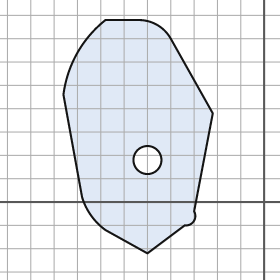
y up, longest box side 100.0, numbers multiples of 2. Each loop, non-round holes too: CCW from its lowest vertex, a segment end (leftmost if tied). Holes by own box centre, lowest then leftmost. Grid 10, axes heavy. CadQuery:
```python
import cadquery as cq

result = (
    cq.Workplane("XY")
    .moveTo(-50.0, -22.0)
    .lineTo(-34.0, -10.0)
    .threePointArc((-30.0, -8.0), (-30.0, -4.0))
    .lineTo(-22.0, 38.0)
    .lineTo(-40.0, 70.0)
    .threePointArc((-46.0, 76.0), (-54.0, 78.0))
    .lineTo(-68.0, 78.0)
    .threePointArc((-80.0, 64.0), (-86.0, 46.0))
    .lineTo(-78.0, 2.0)
    .threePointArc((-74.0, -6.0), (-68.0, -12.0))
    .close()
    .moveTo(-50.0, 18.0)
    .circle(6.0)
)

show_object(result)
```